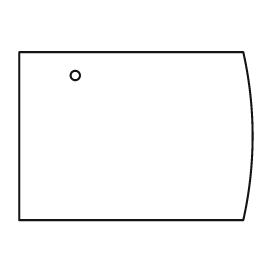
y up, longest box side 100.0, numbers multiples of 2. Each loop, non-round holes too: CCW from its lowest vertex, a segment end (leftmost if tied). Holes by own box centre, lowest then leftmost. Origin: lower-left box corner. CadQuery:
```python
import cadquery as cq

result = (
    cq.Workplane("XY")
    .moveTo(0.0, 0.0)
    .lineTo(96.0, 0.0)
    .threePointArc((100.0, 36.0), (96.0, 72.0))
    .lineTo(0.0, 72.0)
    .close()
    .moveTo(24.0, 62.0)
    .circle(2.0)
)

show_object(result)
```